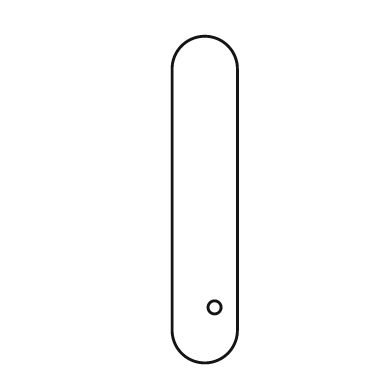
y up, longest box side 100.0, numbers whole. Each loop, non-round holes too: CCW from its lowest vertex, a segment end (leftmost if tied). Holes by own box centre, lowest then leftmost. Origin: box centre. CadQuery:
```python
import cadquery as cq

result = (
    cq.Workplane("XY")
    .moveTo(-10.0, -40.0)
    .threePointArc((0.0, -50.0), (10.0, -40.0))
    .lineTo(10.0, 40.0)
    .threePointArc((0.0, 50.0), (-10.0, 40.0))
    .close()
    .moveTo(3.0, -33.0)
    .circle(2.0)
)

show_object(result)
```